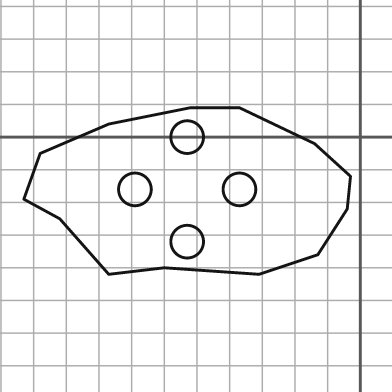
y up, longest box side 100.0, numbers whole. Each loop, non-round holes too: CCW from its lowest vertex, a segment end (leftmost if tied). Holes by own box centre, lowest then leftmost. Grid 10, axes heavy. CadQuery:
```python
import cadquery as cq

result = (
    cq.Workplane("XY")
    .moveTo(-77.0, -42.0)
    .lineTo(-60.0, -40.0)
    .lineTo(-31.0, -42.0)
    .lineTo(-13.0, -36.0)
    .lineTo(-4.0, -22.0)
    .lineTo(-3.0, -12.0)
    .lineTo(-14.0, -2.0)
    .lineTo(-37.0, 9.0)
    .lineTo(-52.0, 9.0)
    .lineTo(-77.0, 4.0)
    .lineTo(-98.0, -5.0)
    .lineTo(-103.0, -19.0)
    .lineTo(-92.0, -25.0)
    .close()
    .moveTo(-53.0, -32.0)
    .circle(5.0)
    .moveTo(-69.0, -16.0)
    .circle(5.0)
    .moveTo(-37.0, -16.0)
    .circle(5.0)
    .moveTo(-53.0, 0.0)
    .circle(5.0)
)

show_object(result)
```